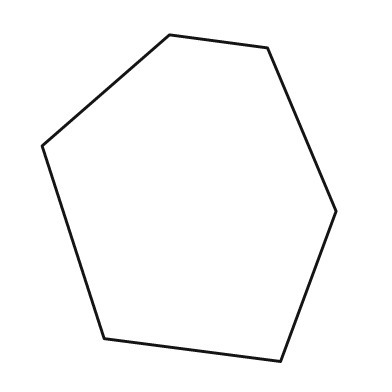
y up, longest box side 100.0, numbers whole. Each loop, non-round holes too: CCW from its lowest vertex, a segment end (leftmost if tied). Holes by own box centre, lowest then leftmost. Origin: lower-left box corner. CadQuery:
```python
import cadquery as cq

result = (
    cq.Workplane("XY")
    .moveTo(73.0, 0.0)
    .lineTo(90.0, 46.0)
    .lineTo(69.0, 96.0)
    .lineTo(39.0, 100.0)
    .lineTo(0.0, 66.0)
    .lineTo(19.0, 7.0)
    .close()
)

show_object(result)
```